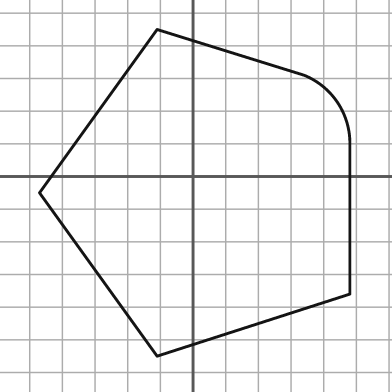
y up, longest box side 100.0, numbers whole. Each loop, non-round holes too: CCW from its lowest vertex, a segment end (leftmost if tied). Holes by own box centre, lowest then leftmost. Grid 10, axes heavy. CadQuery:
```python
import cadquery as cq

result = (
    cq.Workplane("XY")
    .moveTo(-11.0, -55.0)
    .lineTo(48.0, -36.0)
    .lineTo(48.0, 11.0)
    .threePointArc((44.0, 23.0), (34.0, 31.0))
    .lineTo(-11.0, 45.0)
    .lineTo(-47.0, -5.0)
    .close()
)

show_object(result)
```